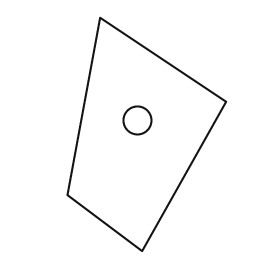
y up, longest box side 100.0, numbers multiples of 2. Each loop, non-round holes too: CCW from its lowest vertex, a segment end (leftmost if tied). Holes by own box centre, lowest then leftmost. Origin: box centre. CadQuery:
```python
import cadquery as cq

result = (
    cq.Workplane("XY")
    .moveTo(-2.0, -50.0)
    .lineTo(34.0, 14.0)
    .lineTo(-20.0, 50.0)
    .lineTo(-34.0, -26.0)
    .close()
    .moveTo(-4.0, 6.0)
    .circle(6.0)
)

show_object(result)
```